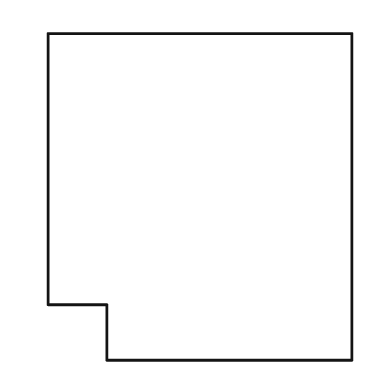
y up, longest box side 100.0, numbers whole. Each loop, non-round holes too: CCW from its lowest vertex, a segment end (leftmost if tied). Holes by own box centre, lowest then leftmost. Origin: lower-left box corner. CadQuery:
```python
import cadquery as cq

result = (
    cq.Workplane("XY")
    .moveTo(18.0, 0.0)
    .lineTo(93.0, 0.0)
    .lineTo(93.0, 100.0)
    .lineTo(0.0, 100.0)
    .lineTo(0.0, 17.0)
    .lineTo(18.0, 17.0)
    .close()
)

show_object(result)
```